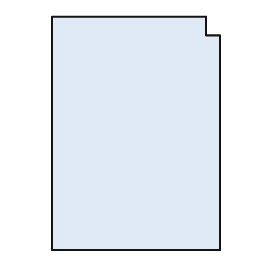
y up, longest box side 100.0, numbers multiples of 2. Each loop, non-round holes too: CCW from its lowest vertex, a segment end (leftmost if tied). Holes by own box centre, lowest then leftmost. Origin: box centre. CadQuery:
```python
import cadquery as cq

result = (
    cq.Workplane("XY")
    .moveTo(-36.0, -50.0)
    .lineTo(36.0, -50.0)
    .lineTo(36.0, 42.0)
    .lineTo(30.0, 42.0)
    .lineTo(30.0, 50.0)
    .lineTo(-36.0, 50.0)
    .close()
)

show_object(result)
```